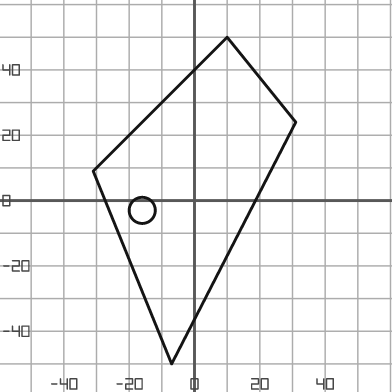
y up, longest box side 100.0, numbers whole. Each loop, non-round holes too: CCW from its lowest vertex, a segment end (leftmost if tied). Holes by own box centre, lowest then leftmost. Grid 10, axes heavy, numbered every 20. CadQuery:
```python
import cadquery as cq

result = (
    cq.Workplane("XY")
    .moveTo(-7.0, -50.0)
    .lineTo(31.0, 24.0)
    .lineTo(10.0, 50.0)
    .lineTo(-31.0, 9.0)
    .close()
    .moveTo(-16.0, -3.0)
    .circle(4.0)
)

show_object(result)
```